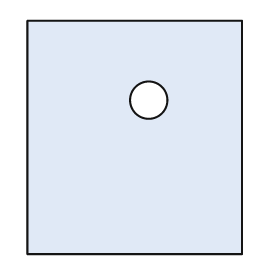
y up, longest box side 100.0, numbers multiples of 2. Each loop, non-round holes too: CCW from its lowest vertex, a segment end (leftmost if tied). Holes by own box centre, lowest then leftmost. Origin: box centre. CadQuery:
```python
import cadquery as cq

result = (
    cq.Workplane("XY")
    .moveTo(-46.0, -50.0)
    .lineTo(46.0, -50.0)
    .lineTo(46.0, 50.0)
    .lineTo(-46.0, 50.0)
    .close()
    .moveTo(6.0, 16.0)
    .circle(8.0)
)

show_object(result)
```